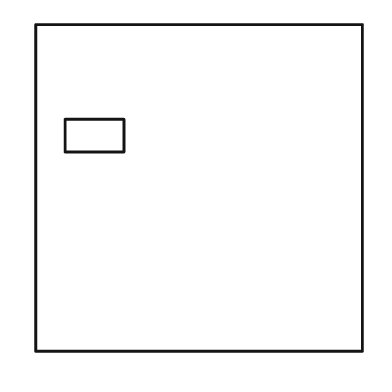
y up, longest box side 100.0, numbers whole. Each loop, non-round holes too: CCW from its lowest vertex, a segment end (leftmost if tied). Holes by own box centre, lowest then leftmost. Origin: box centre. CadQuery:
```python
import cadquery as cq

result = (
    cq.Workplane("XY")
    .moveTo(-50.0, -50.0)
    .lineTo(50.0, -50.0)
    .lineTo(50.0, 50.0)
    .lineTo(-50.0, 50.0)
    .close()
    .moveTo(-41.0, 11.0)
    .lineTo(-23.0, 11.0)
    .lineTo(-23.0, 21.0)
    .lineTo(-41.0, 21.0)
    .close()
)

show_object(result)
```